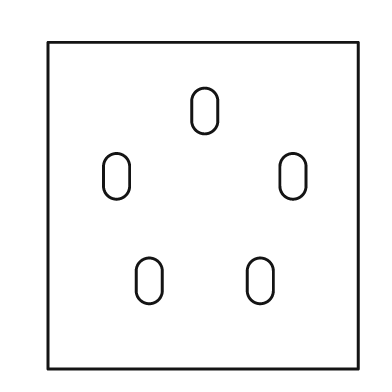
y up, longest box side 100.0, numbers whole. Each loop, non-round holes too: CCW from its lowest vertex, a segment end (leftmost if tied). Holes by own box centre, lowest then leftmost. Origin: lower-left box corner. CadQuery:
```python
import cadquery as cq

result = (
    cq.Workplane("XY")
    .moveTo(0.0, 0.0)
    .lineTo(95.0, 0.0)
    .lineTo(95.0, 100.0)
    .lineTo(0.0, 100.0)
    .close()
    .moveTo(27.0, 24.0)
    .threePointArc((31.0, 20.0), (35.0, 24.0))
    .lineTo(35.0, 30.0)
    .threePointArc((31.0, 34.0), (27.0, 30.0))
    .close()
    .moveTo(61.0, 24.0)
    .threePointArc((65.0, 20.0), (69.0, 24.0))
    .lineTo(69.0, 30.0)
    .threePointArc((65.0, 34.0), (61.0, 30.0))
    .close()
    .moveTo(17.0, 56.0)
    .threePointArc((21.0, 52.0), (25.0, 56.0))
    .lineTo(25.0, 62.0)
    .threePointArc((21.0, 66.0), (17.0, 62.0))
    .close()
    .moveTo(71.0, 56.0)
    .threePointArc((75.0, 52.0), (79.0, 56.0))
    .lineTo(79.0, 62.0)
    .threePointArc((75.0, 66.0), (71.0, 62.0))
    .close()
    .moveTo(44.0, 76.0)
    .threePointArc((48.0, 72.0), (52.0, 76.0))
    .lineTo(52.0, 82.0)
    .threePointArc((48.0, 86.0), (44.0, 82.0))
    .close()
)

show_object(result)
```